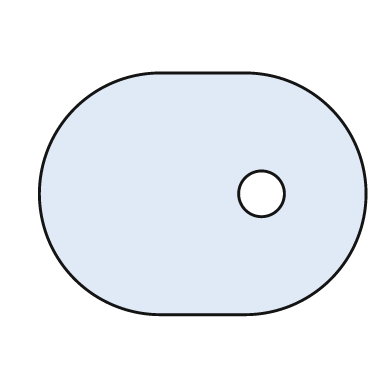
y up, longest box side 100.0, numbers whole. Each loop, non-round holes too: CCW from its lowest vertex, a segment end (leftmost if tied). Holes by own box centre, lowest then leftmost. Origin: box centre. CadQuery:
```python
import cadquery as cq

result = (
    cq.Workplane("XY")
    .moveTo(-13.0, -37.0)
    .lineTo(13.0, -37.0)
    .threePointArc((50.0, 0.0), (13.0, 37.0))
    .lineTo(-13.0, 37.0)
    .threePointArc((-50.0, 0.0), (-13.0, -37.0))
    .close()
    .moveTo(18.0, 0.0)
    .circle(7.0)
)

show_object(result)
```